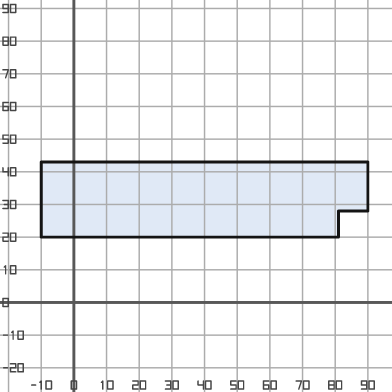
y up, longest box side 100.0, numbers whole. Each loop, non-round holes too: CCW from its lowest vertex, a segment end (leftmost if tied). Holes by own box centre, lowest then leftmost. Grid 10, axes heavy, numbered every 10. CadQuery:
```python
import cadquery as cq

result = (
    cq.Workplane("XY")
    .moveTo(-10.0, 20.0)
    .lineTo(81.0, 20.0)
    .lineTo(81.0, 28.0)
    .lineTo(90.0, 28.0)
    .lineTo(90.0, 43.0)
    .lineTo(-10.0, 43.0)
    .close()
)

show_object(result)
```